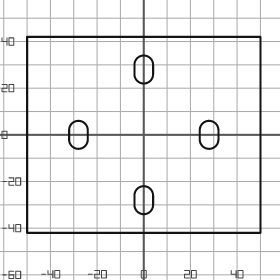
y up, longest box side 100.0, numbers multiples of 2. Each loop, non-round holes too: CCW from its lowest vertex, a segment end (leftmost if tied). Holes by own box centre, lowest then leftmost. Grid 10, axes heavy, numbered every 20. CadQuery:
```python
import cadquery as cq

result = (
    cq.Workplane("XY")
    .moveTo(-50.0, -42.0)
    .lineTo(50.0, -42.0)
    .lineTo(50.0, 42.0)
    .lineTo(-50.0, 42.0)
    .close()
    .moveTo(-4.0, -30.0)
    .threePointArc((0.0, -34.0), (4.0, -30.0))
    .lineTo(4.0, -26.0)
    .threePointArc((0.0, -22.0), (-4.0, -26.0))
    .close()
    .moveTo(-32.0, -2.0)
    .threePointArc((-28.0, -6.0), (-24.0, -2.0))
    .lineTo(-24.0, 2.0)
    .threePointArc((-28.0, 6.0), (-32.0, 2.0))
    .close()
    .moveTo(24.0, -2.0)
    .threePointArc((28.0, -6.0), (32.0, -2.0))
    .lineTo(32.0, 2.0)
    .threePointArc((28.0, 6.0), (24.0, 2.0))
    .close()
    .moveTo(-4.0, 26.0)
    .threePointArc((0.0, 22.0), (4.0, 26.0))
    .lineTo(4.0, 30.0)
    .threePointArc((0.0, 34.0), (-4.0, 30.0))
    .close()
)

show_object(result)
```